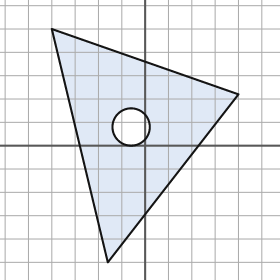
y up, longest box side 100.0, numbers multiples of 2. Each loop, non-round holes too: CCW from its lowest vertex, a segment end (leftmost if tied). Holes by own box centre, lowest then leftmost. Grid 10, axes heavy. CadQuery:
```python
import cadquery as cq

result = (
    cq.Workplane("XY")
    .moveTo(-16.0, -50.0)
    .lineTo(40.0, 22.0)
    .lineTo(-40.0, 50.0)
    .close()
    .moveTo(-6.0, 8.0)
    .circle(8.0)
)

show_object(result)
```